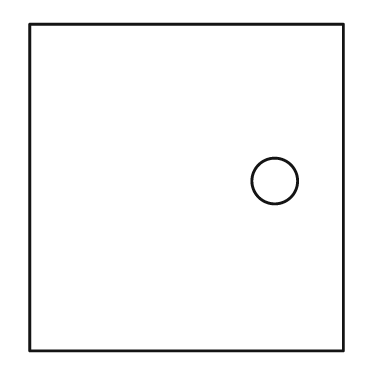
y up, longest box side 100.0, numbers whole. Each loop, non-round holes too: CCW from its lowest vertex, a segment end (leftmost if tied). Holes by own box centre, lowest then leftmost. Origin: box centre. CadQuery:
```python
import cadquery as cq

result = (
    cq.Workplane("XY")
    .moveTo(-48.0, -50.0)
    .lineTo(48.0, -50.0)
    .lineTo(48.0, 50.0)
    .lineTo(-48.0, 50.0)
    .close()
    .moveTo(27.0, 2.0)
    .circle(7.0)
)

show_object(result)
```